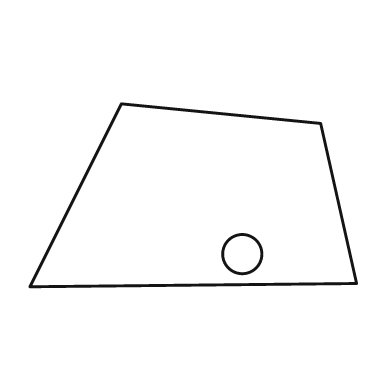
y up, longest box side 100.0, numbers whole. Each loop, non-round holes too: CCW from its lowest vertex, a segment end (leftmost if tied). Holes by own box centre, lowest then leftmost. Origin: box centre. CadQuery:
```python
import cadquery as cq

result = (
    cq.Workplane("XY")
    .moveTo(-50.0, -28.0)
    .lineTo(50.0, -27.0)
    .lineTo(39.0, 22.0)
    .lineTo(-22.0, 28.0)
    .close()
    .moveTo(15.0, -18.0)
    .circle(6.0)
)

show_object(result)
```